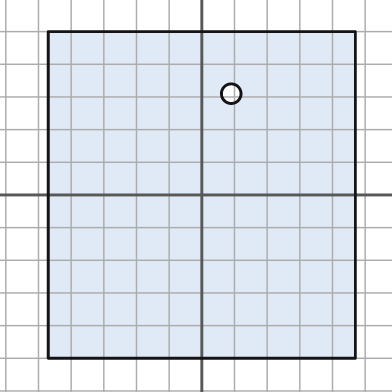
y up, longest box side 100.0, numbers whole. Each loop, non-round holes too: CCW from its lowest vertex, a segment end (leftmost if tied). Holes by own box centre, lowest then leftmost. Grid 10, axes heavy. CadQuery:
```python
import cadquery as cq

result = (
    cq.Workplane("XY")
    .moveTo(-47.0, -50.0)
    .lineTo(47.0, -50.0)
    .lineTo(47.0, 50.0)
    .lineTo(-47.0, 50.0)
    .close()
    .moveTo(9.0, 31.0)
    .circle(3.0)
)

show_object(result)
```